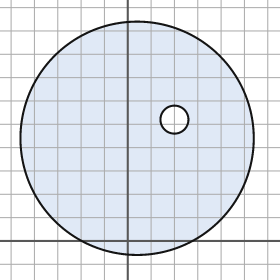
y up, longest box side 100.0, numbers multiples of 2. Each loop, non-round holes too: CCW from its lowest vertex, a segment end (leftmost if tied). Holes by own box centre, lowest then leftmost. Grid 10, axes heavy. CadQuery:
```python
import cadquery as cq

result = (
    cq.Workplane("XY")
    .moveTo(4.0, 44.0)
    .circle(50.0)
    .moveTo(20.0, 52.0)
    .circle(6.0)
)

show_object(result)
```